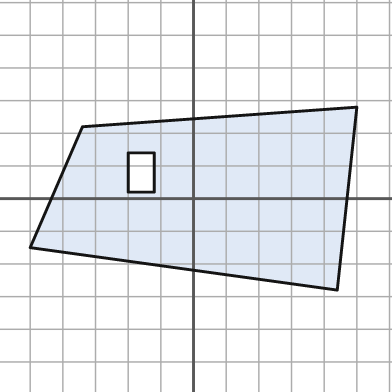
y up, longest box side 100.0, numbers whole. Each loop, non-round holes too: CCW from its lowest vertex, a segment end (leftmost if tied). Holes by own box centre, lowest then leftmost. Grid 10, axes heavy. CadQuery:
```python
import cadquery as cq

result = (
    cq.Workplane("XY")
    .moveTo(44.0, -28.0)
    .lineTo(50.0, 28.0)
    .lineTo(-34.0, 22.0)
    .lineTo(-50.0, -15.0)
    .close()
    .moveTo(-20.0, 2.0)
    .lineTo(-12.0, 2.0)
    .lineTo(-12.0, 14.0)
    .lineTo(-20.0, 14.0)
    .close()
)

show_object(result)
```